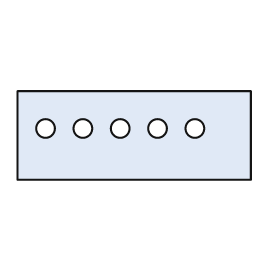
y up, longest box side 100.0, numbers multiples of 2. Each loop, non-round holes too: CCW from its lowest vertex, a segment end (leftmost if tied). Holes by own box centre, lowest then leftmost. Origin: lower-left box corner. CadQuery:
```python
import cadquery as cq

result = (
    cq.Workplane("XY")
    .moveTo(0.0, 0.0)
    .lineTo(100.0, 0.0)
    .lineTo(100.0, 38.0)
    .lineTo(0.0, 38.0)
    .close()
    .moveTo(12.0, 22.0)
    .circle(4.0)
    .moveTo(28.0, 22.0)
    .circle(4.0)
    .moveTo(44.0, 22.0)
    .circle(4.0)
    .moveTo(60.0, 22.0)
    .circle(4.0)
    .moveTo(76.0, 22.0)
    .circle(4.0)
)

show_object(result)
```